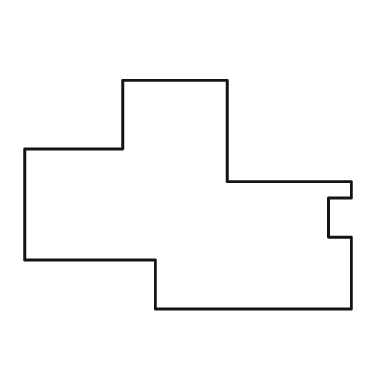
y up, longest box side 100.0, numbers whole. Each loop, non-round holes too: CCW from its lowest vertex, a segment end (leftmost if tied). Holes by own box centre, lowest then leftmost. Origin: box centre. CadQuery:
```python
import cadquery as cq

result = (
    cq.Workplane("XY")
    .moveTo(-10.0, -35.0)
    .lineTo(50.0, -35.0)
    .lineTo(50.0, -13.0)
    .lineTo(43.0, -13.0)
    .lineTo(43.0, -1.0)
    .lineTo(50.0, -1.0)
    .lineTo(50.0, 4.0)
    .lineTo(12.0, 4.0)
    .lineTo(12.0, 35.0)
    .lineTo(-20.0, 35.0)
    .lineTo(-20.0, 14.0)
    .lineTo(-50.0, 14.0)
    .lineTo(-50.0, -20.0)
    .lineTo(-10.0, -20.0)
    .close()
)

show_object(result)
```